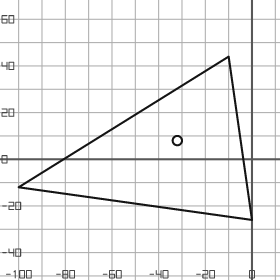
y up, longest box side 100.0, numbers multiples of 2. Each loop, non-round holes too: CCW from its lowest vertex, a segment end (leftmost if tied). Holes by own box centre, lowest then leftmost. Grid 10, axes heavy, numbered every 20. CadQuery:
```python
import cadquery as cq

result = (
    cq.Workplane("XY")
    .moveTo(0.0, -26.0)
    .lineTo(-10.0, 44.0)
    .lineTo(-100.0, -12.0)
    .close()
    .moveTo(-32.0, 8.0)
    .circle(2.0)
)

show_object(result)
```